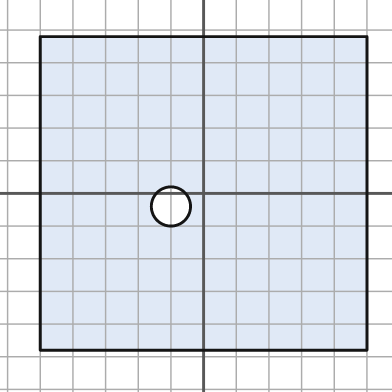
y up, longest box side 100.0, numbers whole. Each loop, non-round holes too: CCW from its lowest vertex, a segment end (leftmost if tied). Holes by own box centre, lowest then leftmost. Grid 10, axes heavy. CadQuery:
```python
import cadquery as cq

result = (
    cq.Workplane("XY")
    .moveTo(-50.0, -48.0)
    .lineTo(50.0, -48.0)
    .lineTo(50.0, 48.0)
    .lineTo(-50.0, 48.0)
    .close()
    .moveTo(-10.0, -4.0)
    .circle(6.0)
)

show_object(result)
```